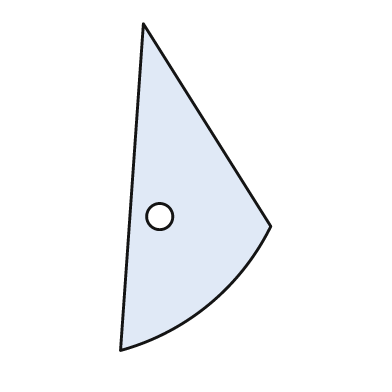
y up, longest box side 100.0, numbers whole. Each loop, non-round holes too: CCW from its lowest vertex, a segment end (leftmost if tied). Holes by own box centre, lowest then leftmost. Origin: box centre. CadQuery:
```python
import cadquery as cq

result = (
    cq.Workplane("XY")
    .moveTo(-23.0, -50.0)
    .threePointArc((4.0, -36.0), (23.0, -12.0))
    .lineTo(-16.0, 50.0)
    .close()
    .moveTo(-11.0, -9.0)
    .circle(4.0)
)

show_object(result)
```